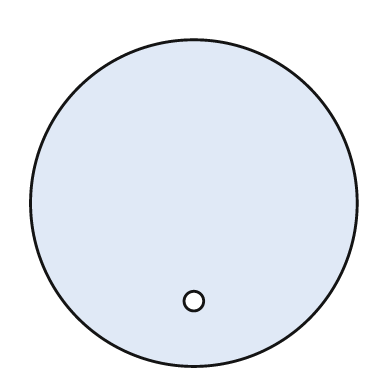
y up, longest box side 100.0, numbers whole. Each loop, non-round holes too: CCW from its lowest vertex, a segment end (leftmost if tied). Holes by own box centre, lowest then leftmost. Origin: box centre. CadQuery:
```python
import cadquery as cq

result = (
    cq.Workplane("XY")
    .moveTo(0.0, 0.0)
    .circle(50.0)
    .moveTo(0.0, -30.0)
    .circle(3.0)
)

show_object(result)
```